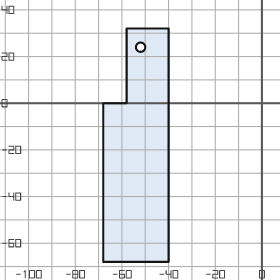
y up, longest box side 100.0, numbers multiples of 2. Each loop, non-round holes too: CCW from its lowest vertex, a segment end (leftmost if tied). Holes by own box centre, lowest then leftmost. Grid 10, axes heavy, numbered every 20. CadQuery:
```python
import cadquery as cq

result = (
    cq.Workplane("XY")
    .moveTo(-68.0, -68.0)
    .lineTo(-40.0, -68.0)
    .lineTo(-40.0, 32.0)
    .lineTo(-58.0, 32.0)
    .lineTo(-58.0, 0.0)
    .lineTo(-68.0, 0.0)
    .close()
    .moveTo(-52.0, 24.0)
    .circle(2.0)
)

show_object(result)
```